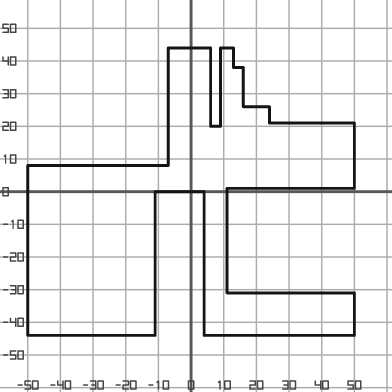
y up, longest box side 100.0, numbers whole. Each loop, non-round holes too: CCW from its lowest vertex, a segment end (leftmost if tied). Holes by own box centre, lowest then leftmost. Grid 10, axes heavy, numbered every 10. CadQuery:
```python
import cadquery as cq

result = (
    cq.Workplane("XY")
    .moveTo(-50.0, -44.0)
    .lineTo(-11.0, -44.0)
    .lineTo(-11.0, 0.0)
    .lineTo(4.0, 0.0)
    .lineTo(4.0, -44.0)
    .lineTo(50.0, -44.0)
    .lineTo(50.0, -31.0)
    .lineTo(11.0, -31.0)
    .lineTo(11.0, 1.0)
    .lineTo(50.0, 1.0)
    .lineTo(50.0, 21.0)
    .lineTo(24.0, 21.0)
    .lineTo(24.0, 26.0)
    .lineTo(16.0, 26.0)
    .lineTo(16.0, 38.0)
    .lineTo(13.0, 38.0)
    .lineTo(13.0, 44.0)
    .lineTo(9.0, 44.0)
    .lineTo(9.0, 20.0)
    .lineTo(6.0, 20.0)
    .lineTo(6.0, 44.0)
    .lineTo(-7.0, 44.0)
    .lineTo(-7.0, 8.0)
    .lineTo(-50.0, 8.0)
    .close()
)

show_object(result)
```